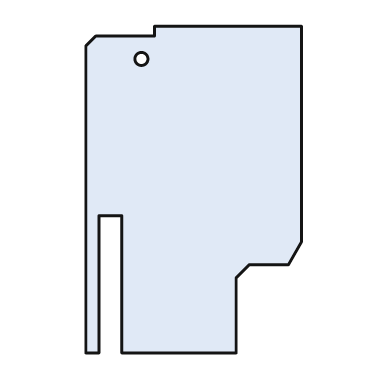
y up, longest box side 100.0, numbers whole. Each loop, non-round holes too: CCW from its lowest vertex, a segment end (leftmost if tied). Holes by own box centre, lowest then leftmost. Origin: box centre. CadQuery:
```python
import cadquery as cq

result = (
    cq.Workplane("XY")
    .moveTo(-33.0, -50.0)
    .lineTo(-29.0, -50.0)
    .lineTo(-29.0, -8.0)
    .lineTo(-22.0, -8.0)
    .lineTo(-22.0, -50.0)
    .lineTo(13.0, -50.0)
    .lineTo(13.0, -27.0)
    .lineTo(17.0, -23.0)
    .lineTo(29.0, -23.0)
    .lineTo(33.0, -16.0)
    .lineTo(33.0, 50.0)
    .lineTo(-12.0, 50.0)
    .lineTo(-12.0, 47.0)
    .lineTo(-30.0, 47.0)
    .lineTo(-33.0, 44.0)
    .close()
    .moveTo(-16.0, 40.0)
    .circle(2.0)
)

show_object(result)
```